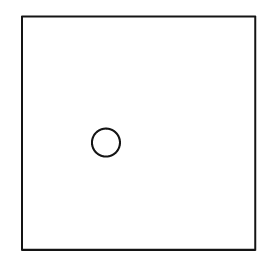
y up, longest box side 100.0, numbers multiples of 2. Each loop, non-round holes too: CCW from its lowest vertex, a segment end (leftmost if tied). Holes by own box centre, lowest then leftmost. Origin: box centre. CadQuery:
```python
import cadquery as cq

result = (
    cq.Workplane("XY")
    .moveTo(-50.0, -50.0)
    .lineTo(50.0, -50.0)
    .lineTo(50.0, 50.0)
    .lineTo(-50.0, 50.0)
    .close()
    .moveTo(-14.0, -4.0)
    .circle(6.0)
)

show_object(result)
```